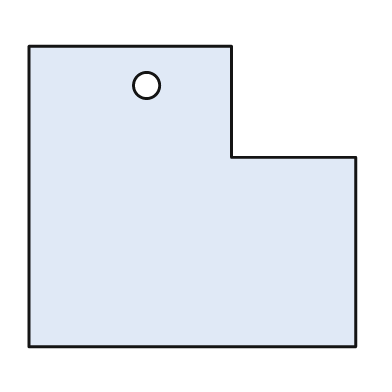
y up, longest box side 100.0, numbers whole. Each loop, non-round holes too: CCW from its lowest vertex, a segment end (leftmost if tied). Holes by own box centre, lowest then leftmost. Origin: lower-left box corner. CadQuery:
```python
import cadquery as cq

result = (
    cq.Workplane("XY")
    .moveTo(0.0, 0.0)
    .lineTo(100.0, 0.0)
    .lineTo(100.0, 58.0)
    .lineTo(62.0, 58.0)
    .lineTo(62.0, 92.0)
    .lineTo(0.0, 92.0)
    .close()
    .moveTo(36.0, 80.0)
    .circle(4.0)
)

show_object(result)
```